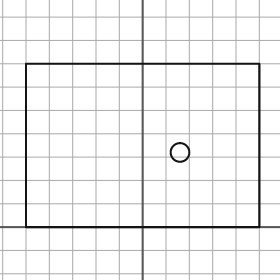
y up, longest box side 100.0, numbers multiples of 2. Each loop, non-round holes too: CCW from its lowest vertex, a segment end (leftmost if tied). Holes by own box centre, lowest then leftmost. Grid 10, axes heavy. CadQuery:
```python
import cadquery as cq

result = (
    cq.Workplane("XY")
    .moveTo(-50.0, 0.0)
    .lineTo(50.0, 0.0)
    .lineTo(50.0, 70.0)
    .lineTo(-50.0, 70.0)
    .close()
    .moveTo(16.0, 32.0)
    .circle(4.0)
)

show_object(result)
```